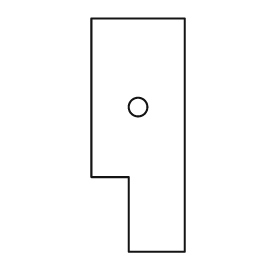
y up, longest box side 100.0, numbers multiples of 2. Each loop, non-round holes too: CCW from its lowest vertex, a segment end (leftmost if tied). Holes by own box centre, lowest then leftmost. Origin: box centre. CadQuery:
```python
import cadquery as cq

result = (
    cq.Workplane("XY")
    .moveTo(-4.0, -50.0)
    .lineTo(20.0, -50.0)
    .lineTo(20.0, 50.0)
    .lineTo(-20.0, 50.0)
    .lineTo(-20.0, -18.0)
    .lineTo(-4.0, -18.0)
    .close()
    .moveTo(0.0, 12.0)
    .circle(4.0)
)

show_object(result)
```